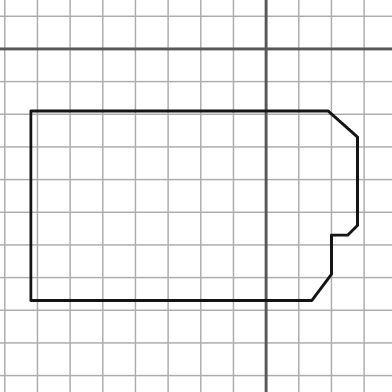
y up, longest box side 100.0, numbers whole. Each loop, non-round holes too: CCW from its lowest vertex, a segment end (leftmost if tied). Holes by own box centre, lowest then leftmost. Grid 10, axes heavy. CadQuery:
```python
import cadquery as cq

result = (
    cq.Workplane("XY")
    .moveTo(-72.0, -77.0)
    .lineTo(14.0, -77.0)
    .lineTo(20.0, -69.0)
    .lineTo(20.0, -57.0)
    .lineTo(25.0, -57.0)
    .lineTo(28.0, -54.0)
    .lineTo(28.0, -27.0)
    .lineTo(19.0, -19.0)
    .lineTo(-72.0, -19.0)
    .close()
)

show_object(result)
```